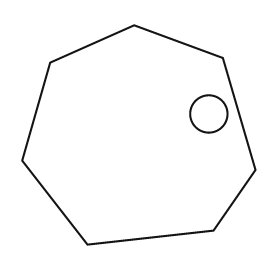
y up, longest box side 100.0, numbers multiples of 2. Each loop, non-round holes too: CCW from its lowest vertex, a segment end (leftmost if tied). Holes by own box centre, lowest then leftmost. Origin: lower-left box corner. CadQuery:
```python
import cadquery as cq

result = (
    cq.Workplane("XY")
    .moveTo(28.0, 0.0)
    .lineTo(82.0, 6.0)
    .lineTo(100.0, 32.0)
    .lineTo(86.0, 80.0)
    .lineTo(48.0, 94.0)
    .lineTo(12.0, 78.0)
    .lineTo(0.0, 36.0)
    .close()
    .moveTo(80.0, 56.0)
    .circle(8.0)
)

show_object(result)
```